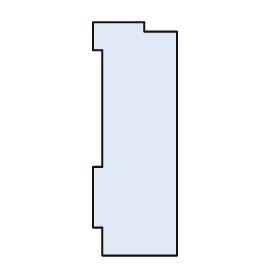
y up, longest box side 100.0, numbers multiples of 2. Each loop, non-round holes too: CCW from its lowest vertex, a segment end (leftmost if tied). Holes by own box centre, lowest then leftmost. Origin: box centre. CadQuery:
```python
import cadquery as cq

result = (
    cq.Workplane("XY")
    .moveTo(-14.0, -50.0)
    .lineTo(18.0, -50.0)
    .lineTo(18.0, 46.0)
    .lineTo(4.0, 46.0)
    .lineTo(4.0, 50.0)
    .lineTo(-18.0, 50.0)
    .lineTo(-18.0, 38.0)
    .lineTo(-14.0, 38.0)
    .lineTo(-14.0, -12.0)
    .lineTo(-18.0, -12.0)
    .lineTo(-18.0, -38.0)
    .lineTo(-14.0, -38.0)
    .close()
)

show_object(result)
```